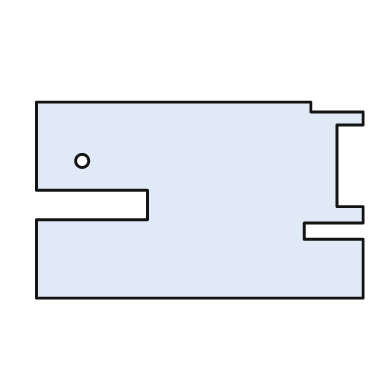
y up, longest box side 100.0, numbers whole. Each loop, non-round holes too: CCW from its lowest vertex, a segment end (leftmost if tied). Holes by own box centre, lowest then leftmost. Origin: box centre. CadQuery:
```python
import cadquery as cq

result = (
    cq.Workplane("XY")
    .moveTo(-50.0, -30.0)
    .lineTo(50.0, -30.0)
    .lineTo(50.0, -12.0)
    .lineTo(32.0, -12.0)
    .lineTo(32.0, -7.0)
    .lineTo(50.0, -7.0)
    .lineTo(50.0, -2.0)
    .lineTo(42.0, -2.0)
    .lineTo(42.0, 23.0)
    .lineTo(50.0, 23.0)
    .lineTo(50.0, 27.0)
    .lineTo(34.0, 27.0)
    .lineTo(34.0, 30.0)
    .lineTo(-50.0, 30.0)
    .lineTo(-50.0, 3.0)
    .lineTo(-16.0, 3.0)
    .lineTo(-16.0, -6.0)
    .lineTo(-50.0, -6.0)
    .close()
    .moveTo(-36.0, 12.0)
    .circle(2.0)
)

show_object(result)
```